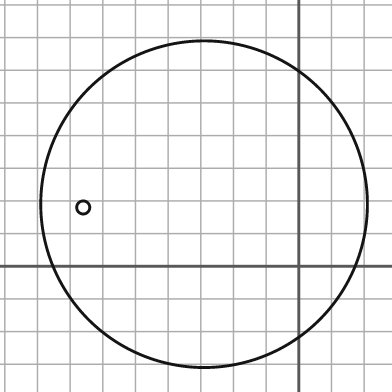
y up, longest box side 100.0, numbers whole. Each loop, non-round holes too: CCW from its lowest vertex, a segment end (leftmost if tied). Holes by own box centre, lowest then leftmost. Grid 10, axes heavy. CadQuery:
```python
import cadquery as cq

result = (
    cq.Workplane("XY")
    .moveTo(-29.0, 19.0)
    .circle(50.0)
    .moveTo(-66.0, 18.0)
    .circle(2.0)
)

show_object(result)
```